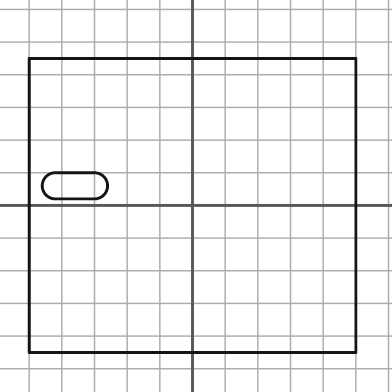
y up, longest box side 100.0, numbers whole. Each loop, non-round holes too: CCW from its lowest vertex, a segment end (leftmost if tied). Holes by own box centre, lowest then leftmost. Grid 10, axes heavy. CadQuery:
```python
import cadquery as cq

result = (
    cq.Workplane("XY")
    .moveTo(-50.0, -45.0)
    .lineTo(50.0, -45.0)
    .lineTo(50.0, 45.0)
    .lineTo(-50.0, 45.0)
    .close()
    .moveTo(-42.0, 2.0)
    .lineTo(-30.0, 2.0)
    .threePointArc((-26.0, 6.0), (-30.0, 10.0))
    .lineTo(-42.0, 10.0)
    .threePointArc((-46.0, 6.0), (-42.0, 2.0))
    .close()
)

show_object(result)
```